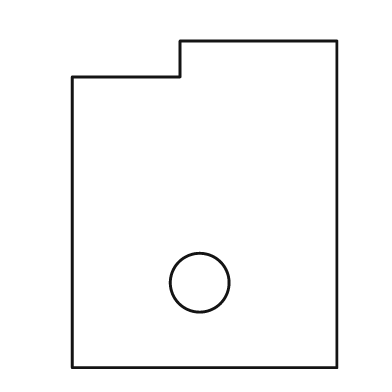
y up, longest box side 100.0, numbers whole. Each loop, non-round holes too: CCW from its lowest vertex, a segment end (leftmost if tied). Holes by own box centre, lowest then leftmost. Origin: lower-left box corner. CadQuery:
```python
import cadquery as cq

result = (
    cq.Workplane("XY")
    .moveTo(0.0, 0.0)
    .lineTo(81.0, 0.0)
    .lineTo(81.0, 100.0)
    .lineTo(33.0, 100.0)
    .lineTo(33.0, 89.0)
    .lineTo(0.0, 89.0)
    .close()
    .moveTo(39.0, 26.0)
    .circle(9.0)
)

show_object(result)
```